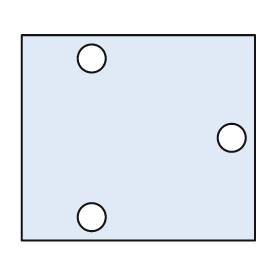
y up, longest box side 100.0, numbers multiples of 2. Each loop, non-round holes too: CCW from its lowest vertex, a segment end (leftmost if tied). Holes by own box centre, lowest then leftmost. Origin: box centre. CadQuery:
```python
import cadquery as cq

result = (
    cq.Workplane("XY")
    .moveTo(-50.0, -44.0)
    .lineTo(50.0, -44.0)
    .lineTo(50.0, 44.0)
    .lineTo(-50.0, 44.0)
    .close()
    .moveTo(-20.0, -34.0)
    .circle(6.0)
    .moveTo(40.0, 0.0)
    .circle(6.0)
    .moveTo(-20.0, 34.0)
    .circle(6.0)
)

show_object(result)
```